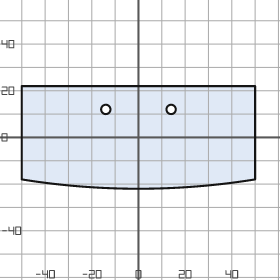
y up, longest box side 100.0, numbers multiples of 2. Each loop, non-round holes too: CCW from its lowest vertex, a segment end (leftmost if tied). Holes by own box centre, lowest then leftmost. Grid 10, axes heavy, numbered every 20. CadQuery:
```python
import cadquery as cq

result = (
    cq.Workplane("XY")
    .moveTo(-50.0, -18.0)
    .threePointArc((0.0, -22.0), (50.0, -18.0))
    .lineTo(50.0, 22.0)
    .lineTo(-50.0, 22.0)
    .close()
    .moveTo(-14.0, 12.0)
    .circle(2.0)
    .moveTo(14.0, 12.0)
    .circle(2.0)
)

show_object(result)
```